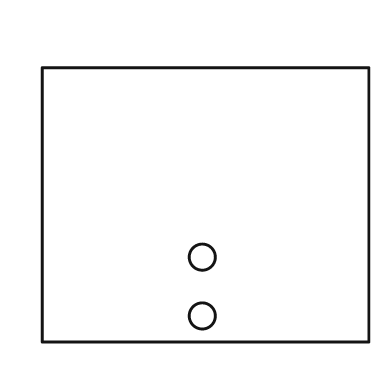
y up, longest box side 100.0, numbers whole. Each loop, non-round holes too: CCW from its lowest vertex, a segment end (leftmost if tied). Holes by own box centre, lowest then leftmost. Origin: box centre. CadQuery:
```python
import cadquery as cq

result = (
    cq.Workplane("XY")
    .moveTo(-50.0, -42.0)
    .lineTo(50.0, -42.0)
    .lineTo(50.0, 42.0)
    .lineTo(-50.0, 42.0)
    .close()
    .moveTo(-1.0, -34.0)
    .circle(4.0)
    .moveTo(-1.0, -16.0)
    .circle(4.0)
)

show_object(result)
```